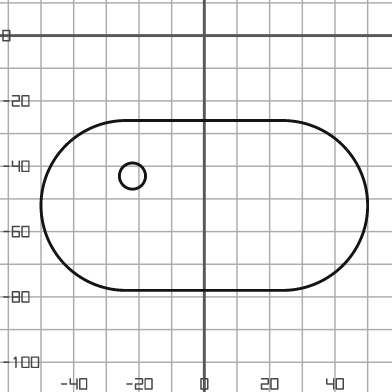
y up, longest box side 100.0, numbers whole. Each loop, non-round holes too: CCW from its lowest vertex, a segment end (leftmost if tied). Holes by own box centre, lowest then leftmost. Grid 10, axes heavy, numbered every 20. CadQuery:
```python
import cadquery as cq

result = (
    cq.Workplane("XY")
    .moveTo(-24.0, -78.0)
    .lineTo(24.0, -78.0)
    .threePointArc((50.0, -52.0), (24.0, -26.0))
    .lineTo(-24.0, -26.0)
    .threePointArc((-50.0, -52.0), (-24.0, -78.0))
    .close()
    .moveTo(-22.0, -43.0)
    .circle(4.0)
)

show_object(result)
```